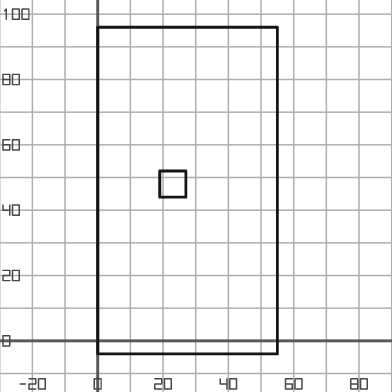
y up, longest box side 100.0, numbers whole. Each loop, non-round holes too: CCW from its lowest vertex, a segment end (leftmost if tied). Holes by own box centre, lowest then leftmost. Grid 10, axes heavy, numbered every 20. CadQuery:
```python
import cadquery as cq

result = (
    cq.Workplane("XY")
    .moveTo(0.0, -4.0)
    .lineTo(55.0, -4.0)
    .lineTo(55.0, 96.0)
    .lineTo(0.0, 96.0)
    .close()
    .moveTo(19.0, 44.0)
    .lineTo(27.0, 44.0)
    .lineTo(27.0, 52.0)
    .lineTo(19.0, 52.0)
    .close()
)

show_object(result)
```